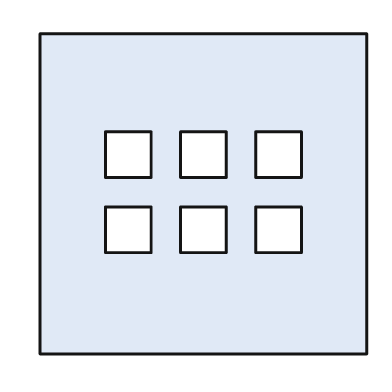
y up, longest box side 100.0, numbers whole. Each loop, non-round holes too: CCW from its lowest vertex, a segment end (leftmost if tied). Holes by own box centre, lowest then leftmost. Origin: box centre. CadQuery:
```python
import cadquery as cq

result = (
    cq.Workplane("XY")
    .moveTo(-50.0, -49.0)
    .lineTo(50.0, -49.0)
    .lineTo(50.0, 49.0)
    .lineTo(-50.0, 49.0)
    .close()
    .moveTo(-30.0, -18.0)
    .lineTo(-16.0, -18.0)
    .lineTo(-16.0, -4.0)
    .lineTo(-30.0, -4.0)
    .close()
    .moveTo(-7.0, -18.0)
    .lineTo(7.0, -18.0)
    .lineTo(7.0, -4.0)
    .lineTo(-7.0, -4.0)
    .close()
    .moveTo(16.0, -18.0)
    .lineTo(30.0, -18.0)
    .lineTo(30.0, -4.0)
    .lineTo(16.0, -4.0)
    .close()
    .moveTo(-30.0, 5.0)
    .lineTo(-16.0, 5.0)
    .lineTo(-16.0, 19.0)
    .lineTo(-30.0, 19.0)
    .close()
    .moveTo(-7.0, 5.0)
    .lineTo(7.0, 5.0)
    .lineTo(7.0, 19.0)
    .lineTo(-7.0, 19.0)
    .close()
    .moveTo(16.0, 5.0)
    .lineTo(30.0, 5.0)
    .lineTo(30.0, 19.0)
    .lineTo(16.0, 19.0)
    .close()
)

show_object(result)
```